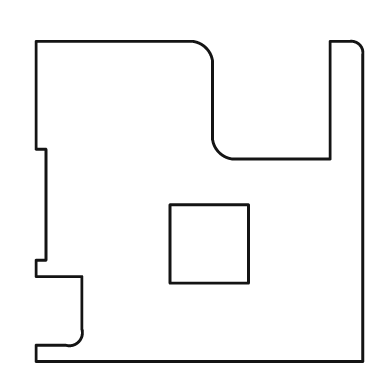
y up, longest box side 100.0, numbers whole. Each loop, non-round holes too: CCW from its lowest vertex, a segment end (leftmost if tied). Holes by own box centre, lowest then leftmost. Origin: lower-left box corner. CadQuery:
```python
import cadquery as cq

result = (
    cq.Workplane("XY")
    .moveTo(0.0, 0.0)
    .lineTo(100.0, 0.0)
    .lineTo(100.0, 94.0)
    .threePointArc((99.0, 97.0), (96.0, 98.0))
    .lineTo(90.0, 98.0)
    .lineTo(90.0, 62.0)
    .lineTo(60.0, 62.0)
    .threePointArc((56.0, 64.0), (54.0, 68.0))
    .lineTo(54.0, 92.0)
    .threePointArc((52.0, 96.0), (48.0, 98.0))
    .lineTo(0.0, 98.0)
    .lineTo(0.0, 65.0)
    .lineTo(3.0, 65.0)
    .lineTo(3.0, 31.0)
    .lineTo(0.0, 31.0)
    .lineTo(0.0, 26.0)
    .lineTo(14.0, 26.0)
    .lineTo(14.0, 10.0)
    .threePointArc((13.0, 6.0), (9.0, 5.0))
    .lineTo(0.0, 5.0)
    .close()
    .moveTo(41.0, 24.0)
    .lineTo(65.0, 24.0)
    .lineTo(65.0, 48.0)
    .lineTo(41.0, 48.0)
    .close()
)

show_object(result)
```